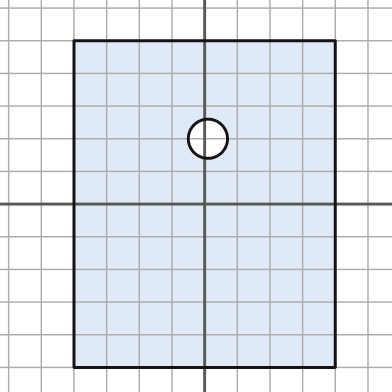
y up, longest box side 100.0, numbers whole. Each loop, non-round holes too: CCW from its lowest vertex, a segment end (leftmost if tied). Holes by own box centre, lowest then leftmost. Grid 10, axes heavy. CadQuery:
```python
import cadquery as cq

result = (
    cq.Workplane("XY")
    .moveTo(-40.0, -50.0)
    .lineTo(40.0, -50.0)
    .lineTo(40.0, 50.0)
    .lineTo(-40.0, 50.0)
    .close()
    .moveTo(1.0, 20.0)
    .circle(6.0)
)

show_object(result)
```